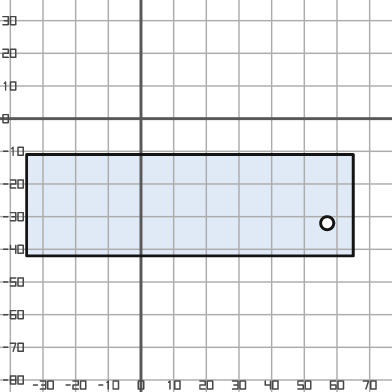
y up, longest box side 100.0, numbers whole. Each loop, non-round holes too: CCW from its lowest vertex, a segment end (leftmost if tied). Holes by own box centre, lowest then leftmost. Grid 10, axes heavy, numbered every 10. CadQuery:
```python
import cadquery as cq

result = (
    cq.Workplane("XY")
    .moveTo(-35.0, -42.0)
    .lineTo(65.0, -42.0)
    .lineTo(65.0, -11.0)
    .lineTo(-35.0, -11.0)
    .close()
    .moveTo(57.0, -32.0)
    .circle(2.0)
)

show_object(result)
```